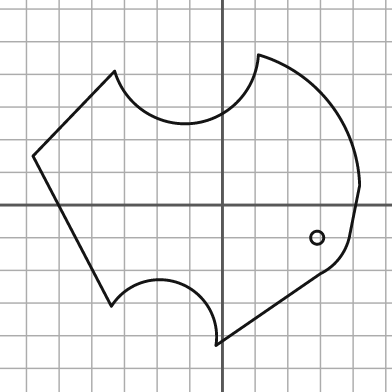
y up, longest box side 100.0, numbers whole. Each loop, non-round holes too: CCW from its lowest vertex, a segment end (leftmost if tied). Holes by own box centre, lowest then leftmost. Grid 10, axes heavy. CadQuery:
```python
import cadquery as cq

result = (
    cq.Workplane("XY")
    .moveTo(-2.0, -43.0)
    .lineTo(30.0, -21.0)
    .threePointArc((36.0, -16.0), (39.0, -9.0))
    .lineTo(42.0, 6.0)
    .threePointArc((33.0, 31.0), (11.0, 46.0))
    .threePointArc((-9.0, 25.0), (-33.0, 41.0))
    .lineTo(-58.0, 15.0)
    .lineTo(-34.0, -31.0)
    .threePointArc((-13.0, -24.0), (-2.0, -43.0))
    .close()
    .moveTo(29.0, -10.0)
    .circle(2.0)
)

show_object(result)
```